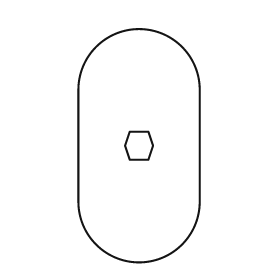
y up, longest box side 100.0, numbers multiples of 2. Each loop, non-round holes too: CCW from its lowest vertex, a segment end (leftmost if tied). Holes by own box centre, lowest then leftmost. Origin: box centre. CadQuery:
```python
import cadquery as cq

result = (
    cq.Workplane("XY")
    .moveTo(-26.0, -24.0)
    .threePointArc((0.0, -50.0), (26.0, -24.0))
    .lineTo(26.0, 24.0)
    .threePointArc((0.0, 50.0), (-26.0, 24.0))
    .close()
    .moveTo(-4.0, -6.0)
    .lineTo(4.0, -6.0)
    .lineTo(6.0, 0.0)
    .lineTo(4.0, 6.0)
    .lineTo(-4.0, 6.0)
    .lineTo(-6.0, 0.0)
    .close()
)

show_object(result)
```